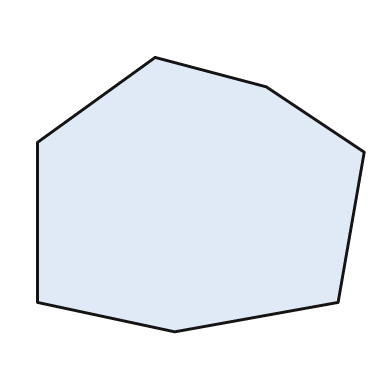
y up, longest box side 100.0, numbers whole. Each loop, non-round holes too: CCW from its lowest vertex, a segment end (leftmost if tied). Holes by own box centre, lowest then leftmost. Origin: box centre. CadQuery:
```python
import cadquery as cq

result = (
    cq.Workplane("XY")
    .moveTo(-8.0, -42.0)
    .lineTo(42.0, -33.0)
    .lineTo(50.0, 13.0)
    .lineTo(20.0, 33.0)
    .lineTo(-14.0, 42.0)
    .lineTo(-50.0, 16.0)
    .lineTo(-50.0, -33.0)
    .close()
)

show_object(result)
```